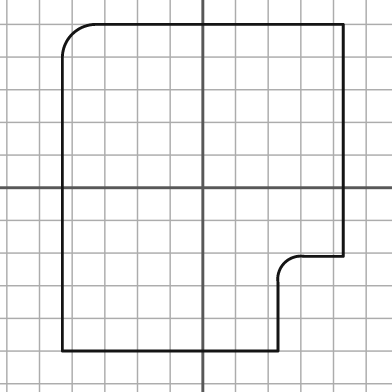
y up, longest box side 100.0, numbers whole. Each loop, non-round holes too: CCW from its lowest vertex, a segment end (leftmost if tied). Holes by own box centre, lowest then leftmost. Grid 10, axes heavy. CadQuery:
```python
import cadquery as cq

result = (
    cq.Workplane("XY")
    .moveTo(-43.0, -50.0)
    .lineTo(23.0, -50.0)
    .lineTo(23.0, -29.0)
    .threePointArc((25.0, -23.0), (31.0, -21.0))
    .lineTo(43.0, -21.0)
    .lineTo(43.0, 50.0)
    .lineTo(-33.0, 50.0)
    .threePointArc((-40.0, 47.0), (-43.0, 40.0))
    .close()
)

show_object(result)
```